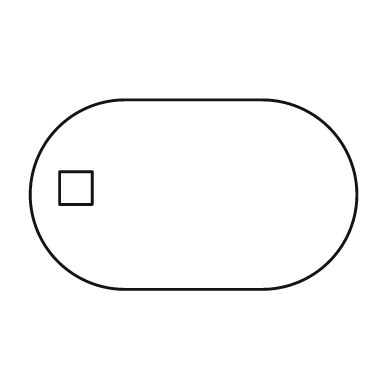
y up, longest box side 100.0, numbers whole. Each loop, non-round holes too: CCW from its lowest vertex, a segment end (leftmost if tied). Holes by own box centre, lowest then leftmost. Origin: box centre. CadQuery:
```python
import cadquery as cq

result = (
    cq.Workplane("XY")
    .moveTo(-21.0, -29.0)
    .lineTo(21.0, -29.0)
    .threePointArc((50.0, 0.0), (21.0, 29.0))
    .lineTo(-21.0, 29.0)
    .threePointArc((-50.0, 0.0), (-21.0, -29.0))
    .close()
    .moveTo(-41.0, -3.0)
    .lineTo(-31.0, -3.0)
    .lineTo(-31.0, 7.0)
    .lineTo(-41.0, 7.0)
    .close()
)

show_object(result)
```